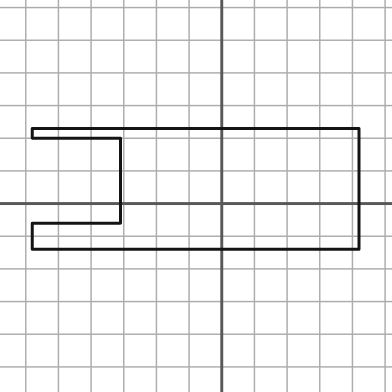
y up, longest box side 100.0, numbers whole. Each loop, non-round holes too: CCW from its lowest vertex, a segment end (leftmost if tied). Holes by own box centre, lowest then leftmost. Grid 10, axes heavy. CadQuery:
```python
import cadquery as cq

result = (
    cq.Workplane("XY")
    .moveTo(-58.0, -14.0)
    .lineTo(42.0, -14.0)
    .lineTo(42.0, 23.0)
    .lineTo(-58.0, 23.0)
    .lineTo(-58.0, 20.0)
    .lineTo(-31.0, 20.0)
    .lineTo(-31.0, -6.0)
    .lineTo(-58.0, -6.0)
    .close()
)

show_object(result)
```